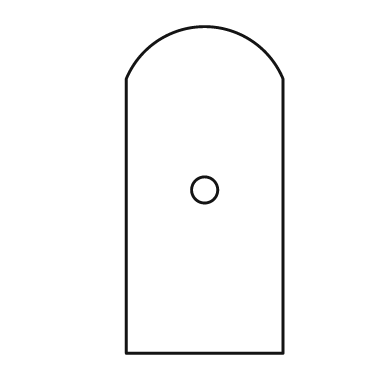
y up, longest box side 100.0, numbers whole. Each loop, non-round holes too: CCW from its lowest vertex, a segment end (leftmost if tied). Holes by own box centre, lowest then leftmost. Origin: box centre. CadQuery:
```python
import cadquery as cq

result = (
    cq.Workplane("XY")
    .moveTo(-24.0, -50.0)
    .lineTo(24.0, -50.0)
    .lineTo(24.0, 34.0)
    .threePointArc((0.0, 50.0), (-24.0, 34.0))
    .close()
    .moveTo(0.0, 0.0)
    .circle(4.0)
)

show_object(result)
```